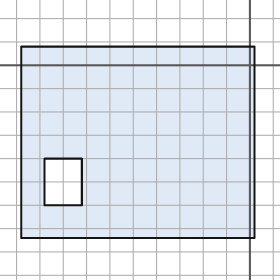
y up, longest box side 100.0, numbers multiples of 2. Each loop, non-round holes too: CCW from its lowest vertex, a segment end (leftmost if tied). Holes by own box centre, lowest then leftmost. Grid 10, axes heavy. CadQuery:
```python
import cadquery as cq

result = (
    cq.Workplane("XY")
    .moveTo(-98.0, -74.0)
    .lineTo(2.0, -74.0)
    .lineTo(2.0, 8.0)
    .lineTo(-98.0, 8.0)
    .close()
    .moveTo(-88.0, -60.0)
    .lineTo(-72.0, -60.0)
    .lineTo(-72.0, -40.0)
    .lineTo(-88.0, -40.0)
    .close()
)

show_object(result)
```